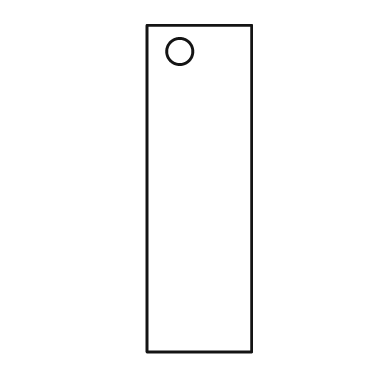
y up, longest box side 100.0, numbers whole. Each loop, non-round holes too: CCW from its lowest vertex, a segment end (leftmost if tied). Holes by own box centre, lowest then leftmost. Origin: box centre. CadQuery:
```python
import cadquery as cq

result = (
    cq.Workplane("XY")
    .moveTo(-16.0, -50.0)
    .lineTo(16.0, -50.0)
    .lineTo(16.0, 50.0)
    .lineTo(-16.0, 50.0)
    .close()
    .moveTo(-6.0, 42.0)
    .circle(4.0)
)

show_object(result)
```